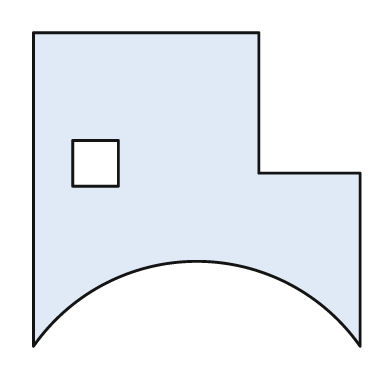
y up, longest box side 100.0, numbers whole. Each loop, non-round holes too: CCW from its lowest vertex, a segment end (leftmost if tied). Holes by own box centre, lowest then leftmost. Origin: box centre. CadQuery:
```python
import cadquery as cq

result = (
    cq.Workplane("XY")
    .moveTo(-50.0, -48.0)
    .threePointArc((0.0, -22.0), (50.0, -48.0))
    .lineTo(50.0, 5.0)
    .lineTo(19.0, 5.0)
    .lineTo(19.0, 48.0)
    .lineTo(-50.0, 48.0)
    .close()
    .moveTo(-38.0, 1.0)
    .lineTo(-24.0, 1.0)
    .lineTo(-24.0, 15.0)
    .lineTo(-38.0, 15.0)
    .close()
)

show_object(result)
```